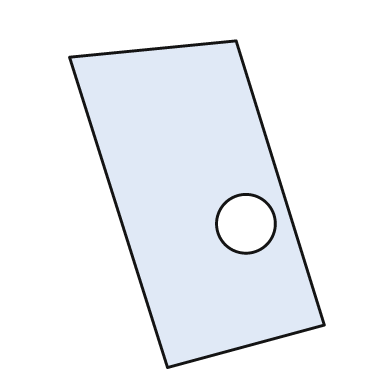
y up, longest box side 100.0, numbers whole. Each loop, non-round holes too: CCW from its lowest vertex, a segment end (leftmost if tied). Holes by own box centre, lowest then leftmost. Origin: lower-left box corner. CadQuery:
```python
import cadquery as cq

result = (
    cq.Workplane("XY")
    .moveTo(30.0, 0.0)
    .lineTo(78.0, 13.0)
    .lineTo(51.0, 100.0)
    .lineTo(0.0, 95.0)
    .close()
    .moveTo(54.0, 44.0)
    .circle(9.0)
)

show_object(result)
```